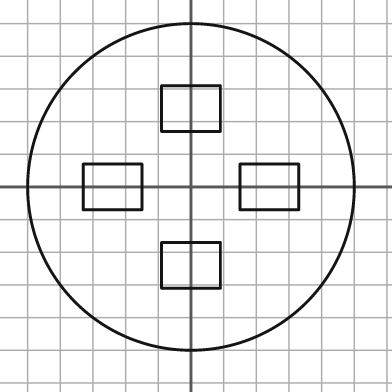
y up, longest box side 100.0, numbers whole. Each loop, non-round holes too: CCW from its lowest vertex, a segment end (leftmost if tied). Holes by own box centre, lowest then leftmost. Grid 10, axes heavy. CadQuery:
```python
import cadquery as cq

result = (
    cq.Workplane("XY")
    .moveTo(0.0, 0.0)
    .circle(50.0)
    .moveTo(-9.0, -31.0)
    .lineTo(9.0, -31.0)
    .lineTo(9.0, -17.0)
    .lineTo(-9.0, -17.0)
    .close()
    .moveTo(-33.0, -7.0)
    .lineTo(-15.0, -7.0)
    .lineTo(-15.0, 7.0)
    .lineTo(-33.0, 7.0)
    .close()
    .moveTo(15.0, -7.0)
    .lineTo(33.0, -7.0)
    .lineTo(33.0, 7.0)
    .lineTo(15.0, 7.0)
    .close()
    .moveTo(-9.0, 17.0)
    .lineTo(9.0, 17.0)
    .lineTo(9.0, 31.0)
    .lineTo(-9.0, 31.0)
    .close()
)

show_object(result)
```